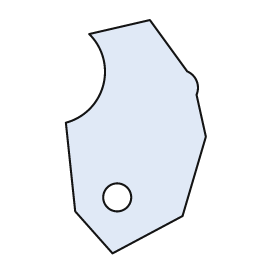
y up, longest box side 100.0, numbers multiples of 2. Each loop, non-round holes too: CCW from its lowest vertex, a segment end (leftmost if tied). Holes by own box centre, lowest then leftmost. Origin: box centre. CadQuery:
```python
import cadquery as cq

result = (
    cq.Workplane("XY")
    .moveTo(-10.0, -50.0)
    .lineTo(20.0, -34.0)
    .lineTo(30.0, 0.0)
    .lineTo(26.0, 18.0)
    .threePointArc((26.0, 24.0), (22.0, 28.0))
    .lineTo(6.0, 50.0)
    .lineTo(-20.0, 44.0)
    .threePointArc((-14.0, 22.0), (-30.0, 6.0))
    .lineTo(-26.0, -32.0)
    .close()
    .moveTo(-8.0, -26.0)
    .circle(6.0)
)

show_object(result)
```